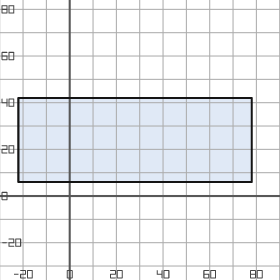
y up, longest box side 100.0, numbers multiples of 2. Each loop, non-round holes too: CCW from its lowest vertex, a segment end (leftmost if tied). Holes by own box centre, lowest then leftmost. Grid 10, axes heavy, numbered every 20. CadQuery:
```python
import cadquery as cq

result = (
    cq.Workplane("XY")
    .moveTo(-22.0, 6.0)
    .lineTo(78.0, 6.0)
    .lineTo(78.0, 42.0)
    .lineTo(-22.0, 42.0)
    .close()
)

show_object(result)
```